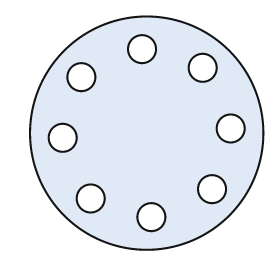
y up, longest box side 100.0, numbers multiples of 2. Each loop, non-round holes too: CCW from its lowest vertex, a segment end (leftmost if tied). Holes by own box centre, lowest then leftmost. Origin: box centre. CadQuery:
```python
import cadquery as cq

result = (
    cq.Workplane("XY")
    .moveTo(0.0, 0.0)
    .circle(50.0)
    .moveTo(2.0, -36.0)
    .circle(6.0)
    .moveTo(-24.0, -28.0)
    .circle(6.0)
    .moveTo(28.0, -24.0)
    .circle(6.0)
    .moveTo(-36.0, -2.0)
    .circle(6.0)
    .moveTo(36.0, 2.0)
    .circle(6.0)
    .moveTo(-28.0, 24.0)
    .circle(6.0)
    .moveTo(24.0, 28.0)
    .circle(6.0)
    .moveTo(-2.0, 36.0)
    .circle(6.0)
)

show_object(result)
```